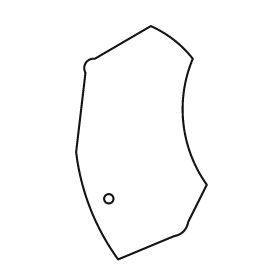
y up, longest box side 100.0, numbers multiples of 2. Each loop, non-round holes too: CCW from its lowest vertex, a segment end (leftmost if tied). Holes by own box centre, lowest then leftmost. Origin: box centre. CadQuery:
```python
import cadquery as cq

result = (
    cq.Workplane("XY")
    .moveTo(-10.0, -50.0)
    .lineTo(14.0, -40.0)
    .threePointArc((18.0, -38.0), (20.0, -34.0))
    .lineTo(28.0, -18.0)
    .threePointArc((18.0, 8.0), (22.0, 36.0))
    .threePointArc((14.0, 44.0), (4.0, 50.0))
    .lineTo(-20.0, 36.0)
    .threePointArc((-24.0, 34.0), (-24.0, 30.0))
    .lineTo(-28.0, -4.0)
    .threePointArc((-22.0, -28.0), (-10.0, -50.0))
    .close()
    .moveTo(-14.0, -24.0)
    .circle(2.0)
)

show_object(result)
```